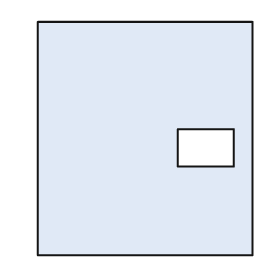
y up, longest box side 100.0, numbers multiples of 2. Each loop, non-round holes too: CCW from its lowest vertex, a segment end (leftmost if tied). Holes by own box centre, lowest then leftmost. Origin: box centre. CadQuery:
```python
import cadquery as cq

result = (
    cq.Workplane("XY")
    .moveTo(-46.0, -50.0)
    .lineTo(46.0, -50.0)
    .lineTo(46.0, 50.0)
    .lineTo(-46.0, 50.0)
    .close()
    .moveTo(14.0, -12.0)
    .lineTo(38.0, -12.0)
    .lineTo(38.0, 4.0)
    .lineTo(14.0, 4.0)
    .close()
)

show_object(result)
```